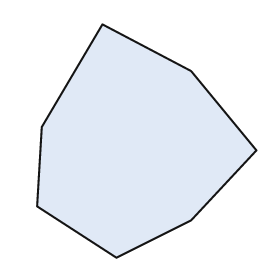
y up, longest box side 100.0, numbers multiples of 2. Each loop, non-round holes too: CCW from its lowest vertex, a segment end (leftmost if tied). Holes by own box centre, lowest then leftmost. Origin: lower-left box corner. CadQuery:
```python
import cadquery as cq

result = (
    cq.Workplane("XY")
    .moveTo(34.0, 0.0)
    .lineTo(66.0, 16.0)
    .lineTo(94.0, 46.0)
    .lineTo(66.0, 80.0)
    .lineTo(28.0, 100.0)
    .lineTo(2.0, 56.0)
    .lineTo(0.0, 22.0)
    .close()
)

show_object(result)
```